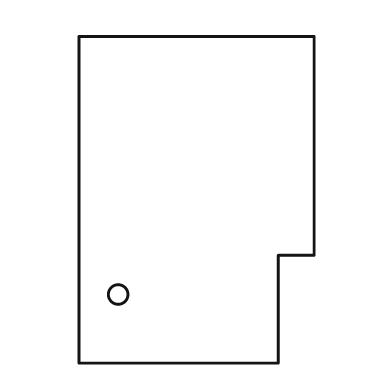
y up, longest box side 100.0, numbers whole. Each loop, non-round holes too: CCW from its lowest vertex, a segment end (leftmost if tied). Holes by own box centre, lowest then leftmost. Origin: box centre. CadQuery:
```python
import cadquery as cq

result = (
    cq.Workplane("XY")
    .moveTo(-36.0, -50.0)
    .lineTo(25.0, -50.0)
    .lineTo(25.0, -17.0)
    .lineTo(36.0, -17.0)
    .lineTo(36.0, 50.0)
    .lineTo(-36.0, 50.0)
    .close()
    .moveTo(-24.0, -29.0)
    .circle(3.0)
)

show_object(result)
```